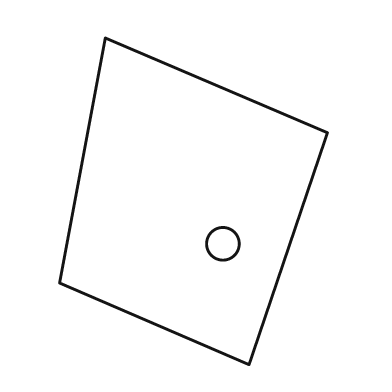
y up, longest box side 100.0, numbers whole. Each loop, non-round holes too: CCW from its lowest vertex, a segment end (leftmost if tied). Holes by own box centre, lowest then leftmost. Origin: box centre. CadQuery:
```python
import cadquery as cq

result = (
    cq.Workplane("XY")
    .moveTo(17.0, -50.0)
    .lineTo(41.0, 21.0)
    .lineTo(-27.0, 50.0)
    .lineTo(-41.0, -25.0)
    .close()
    .moveTo(9.0, -13.0)
    .circle(5.0)
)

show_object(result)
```